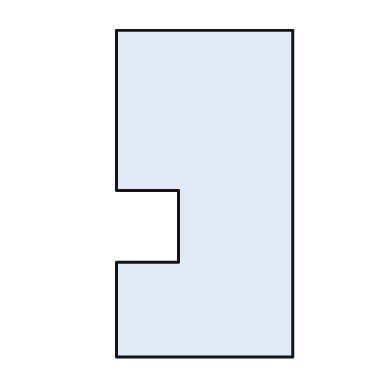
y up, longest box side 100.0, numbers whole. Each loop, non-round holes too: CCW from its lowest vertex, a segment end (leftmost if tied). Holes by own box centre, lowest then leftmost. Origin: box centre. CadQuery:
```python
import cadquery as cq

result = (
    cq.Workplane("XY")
    .moveTo(-27.0, -50.0)
    .lineTo(27.0, -50.0)
    .lineTo(27.0, 50.0)
    .lineTo(-27.0, 50.0)
    .lineTo(-27.0, 1.0)
    .lineTo(-8.0, 1.0)
    .lineTo(-8.0, -21.0)
    .lineTo(-27.0, -21.0)
    .close()
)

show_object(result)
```